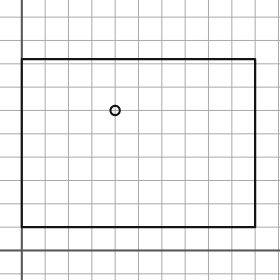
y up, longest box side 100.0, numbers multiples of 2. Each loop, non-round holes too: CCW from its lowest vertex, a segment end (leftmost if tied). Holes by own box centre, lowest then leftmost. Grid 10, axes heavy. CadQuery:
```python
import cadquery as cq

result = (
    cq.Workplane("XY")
    .moveTo(0.0, 10.0)
    .lineTo(100.0, 10.0)
    .lineTo(100.0, 82.0)
    .lineTo(0.0, 82.0)
    .close()
    .moveTo(40.0, 60.0)
    .circle(2.0)
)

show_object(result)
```